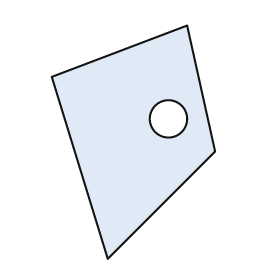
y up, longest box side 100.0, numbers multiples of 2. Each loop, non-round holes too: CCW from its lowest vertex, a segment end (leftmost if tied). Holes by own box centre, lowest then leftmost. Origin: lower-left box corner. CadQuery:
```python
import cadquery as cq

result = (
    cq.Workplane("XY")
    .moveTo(24.0, 0.0)
    .lineTo(70.0, 46.0)
    .lineTo(58.0, 100.0)
    .lineTo(0.0, 78.0)
    .close()
    .moveTo(50.0, 60.0)
    .circle(8.0)
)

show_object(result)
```